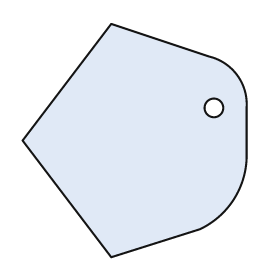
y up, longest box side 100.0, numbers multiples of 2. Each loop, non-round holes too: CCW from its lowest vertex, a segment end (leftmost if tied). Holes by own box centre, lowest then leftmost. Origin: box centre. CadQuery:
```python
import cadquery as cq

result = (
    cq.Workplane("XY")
    .moveTo(-10.0, -50.0)
    .lineTo(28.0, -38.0)
    .threePointArc((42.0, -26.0), (48.0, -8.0))
    .lineTo(48.0, 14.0)
    .threePointArc((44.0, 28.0), (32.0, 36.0))
    .lineTo(-10.0, 50.0)
    .lineTo(-48.0, 0.0)
    .close()
    .moveTo(34.0, 14.0)
    .circle(4.0)
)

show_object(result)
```